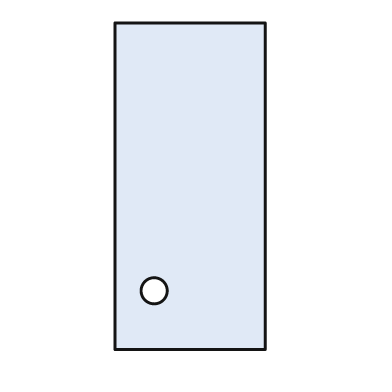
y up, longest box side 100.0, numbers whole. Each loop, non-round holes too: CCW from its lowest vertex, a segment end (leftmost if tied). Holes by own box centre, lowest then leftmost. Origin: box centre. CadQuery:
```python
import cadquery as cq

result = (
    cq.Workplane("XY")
    .moveTo(-23.0, -50.0)
    .lineTo(23.0, -50.0)
    .lineTo(23.0, 50.0)
    .lineTo(-23.0, 50.0)
    .close()
    .moveTo(-11.0, -32.0)
    .circle(4.0)
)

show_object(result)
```